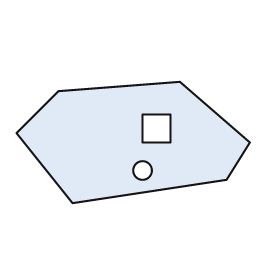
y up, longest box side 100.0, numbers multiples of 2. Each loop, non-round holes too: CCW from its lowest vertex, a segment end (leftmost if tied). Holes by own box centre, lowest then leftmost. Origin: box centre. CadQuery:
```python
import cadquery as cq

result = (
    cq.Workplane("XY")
    .moveTo(-26.0, -26.0)
    .lineTo(40.0, -16.0)
    .lineTo(50.0, 0.0)
    .lineTo(20.0, 26.0)
    .lineTo(-32.0, 22.0)
    .lineTo(-50.0, 4.0)
    .close()
    .moveTo(4.0, -12.0)
    .circle(4.0)
    .moveTo(4.0, 0.0)
    .lineTo(16.0, 0.0)
    .lineTo(16.0, 12.0)
    .lineTo(4.0, 12.0)
    .close()
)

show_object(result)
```